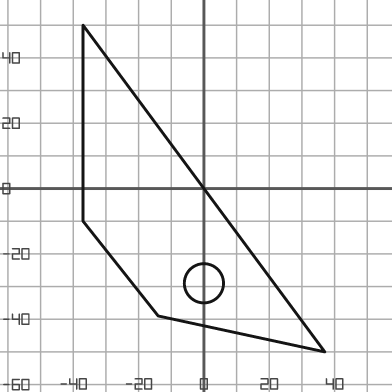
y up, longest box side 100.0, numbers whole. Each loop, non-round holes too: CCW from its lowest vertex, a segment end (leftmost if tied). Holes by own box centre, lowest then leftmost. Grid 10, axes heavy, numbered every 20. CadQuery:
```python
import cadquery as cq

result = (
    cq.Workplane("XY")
    .moveTo(37.0, -50.0)
    .lineTo(-37.0, 50.0)
    .lineTo(-37.0, -10.0)
    .lineTo(-14.0, -39.0)
    .close()
    .moveTo(0.0, -29.0)
    .circle(6.0)
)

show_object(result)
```